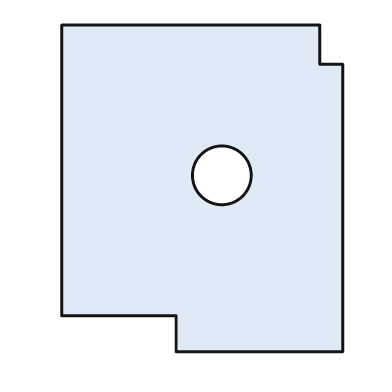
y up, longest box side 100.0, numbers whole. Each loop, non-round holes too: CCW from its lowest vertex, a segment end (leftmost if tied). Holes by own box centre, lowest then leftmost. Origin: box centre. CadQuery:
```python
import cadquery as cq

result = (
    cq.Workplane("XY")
    .moveTo(-8.0, -50.0)
    .lineTo(43.0, -50.0)
    .lineTo(43.0, 38.0)
    .lineTo(36.0, 38.0)
    .lineTo(36.0, 50.0)
    .lineTo(-43.0, 50.0)
    .lineTo(-43.0, -39.0)
    .lineTo(-8.0, -39.0)
    .close()
    .moveTo(6.0, 4.0)
    .circle(9.0)
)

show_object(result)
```